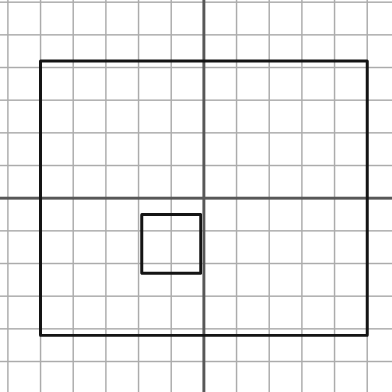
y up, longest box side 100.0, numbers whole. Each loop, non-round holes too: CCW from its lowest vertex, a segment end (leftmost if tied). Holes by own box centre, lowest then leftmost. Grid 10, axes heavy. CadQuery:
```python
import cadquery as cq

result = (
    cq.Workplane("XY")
    .moveTo(-50.0, -42.0)
    .lineTo(50.0, -42.0)
    .lineTo(50.0, 42.0)
    .lineTo(-50.0, 42.0)
    .close()
    .moveTo(-19.0, -23.0)
    .lineTo(-1.0, -23.0)
    .lineTo(-1.0, -5.0)
    .lineTo(-19.0, -5.0)
    .close()
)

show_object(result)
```